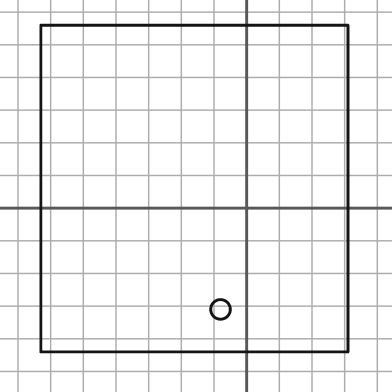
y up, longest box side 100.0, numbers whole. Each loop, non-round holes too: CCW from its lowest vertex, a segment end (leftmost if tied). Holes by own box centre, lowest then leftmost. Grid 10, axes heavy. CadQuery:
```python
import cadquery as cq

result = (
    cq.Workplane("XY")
    .moveTo(-63.0, -44.0)
    .lineTo(31.0, -44.0)
    .lineTo(31.0, 56.0)
    .lineTo(-63.0, 56.0)
    .close()
    .moveTo(-8.0, -31.0)
    .circle(3.0)
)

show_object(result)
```